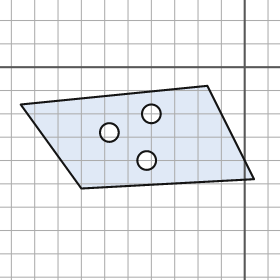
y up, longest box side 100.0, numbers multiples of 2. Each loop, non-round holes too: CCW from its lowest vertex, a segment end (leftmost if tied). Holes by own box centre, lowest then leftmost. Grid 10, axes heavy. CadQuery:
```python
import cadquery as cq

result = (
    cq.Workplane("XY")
    .moveTo(-70.0, -52.0)
    .lineTo(4.0, -48.0)
    .lineTo(-16.0, -8.0)
    .lineTo(-96.0, -16.0)
    .close()
    .moveTo(-42.0, -40.0)
    .circle(4.0)
    .moveTo(-58.0, -28.0)
    .circle(4.0)
    .moveTo(-40.0, -20.0)
    .circle(4.0)
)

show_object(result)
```